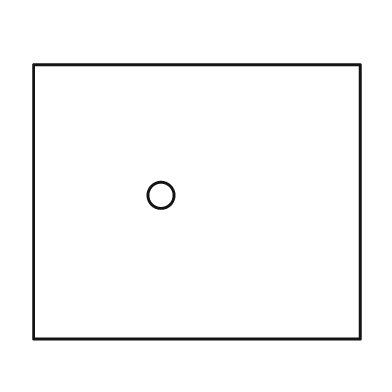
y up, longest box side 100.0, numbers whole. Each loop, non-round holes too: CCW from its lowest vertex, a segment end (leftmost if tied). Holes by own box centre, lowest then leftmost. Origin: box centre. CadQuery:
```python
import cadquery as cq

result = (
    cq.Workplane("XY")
    .moveTo(-50.0, -42.0)
    .lineTo(50.0, -42.0)
    .lineTo(50.0, 42.0)
    .lineTo(-50.0, 42.0)
    .close()
    .moveTo(-11.0, 2.0)
    .circle(4.0)
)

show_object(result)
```